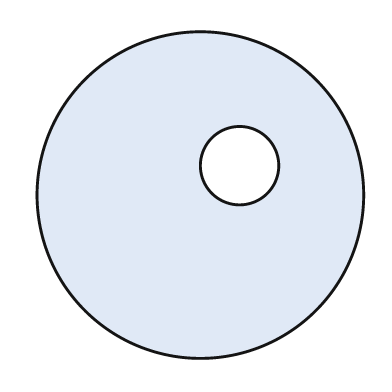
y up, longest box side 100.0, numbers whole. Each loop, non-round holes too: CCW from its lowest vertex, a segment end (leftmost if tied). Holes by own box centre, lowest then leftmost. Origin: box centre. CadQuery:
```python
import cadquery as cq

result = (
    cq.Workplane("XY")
    .moveTo(0.0, 0.0)
    .circle(50.0)
    .moveTo(12.0, 9.0)
    .circle(12.0)
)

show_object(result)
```